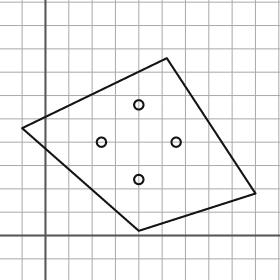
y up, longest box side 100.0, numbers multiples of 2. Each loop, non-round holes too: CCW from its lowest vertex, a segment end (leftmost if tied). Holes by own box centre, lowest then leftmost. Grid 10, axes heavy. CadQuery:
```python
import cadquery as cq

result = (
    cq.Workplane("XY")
    .moveTo(40.0, 2.0)
    .lineTo(90.0, 18.0)
    .lineTo(52.0, 76.0)
    .lineTo(-10.0, 46.0)
    .close()
    .moveTo(40.0, 24.0)
    .circle(2.0)
    .moveTo(24.0, 40.0)
    .circle(2.0)
    .moveTo(56.0, 40.0)
    .circle(2.0)
    .moveTo(40.0, 56.0)
    .circle(2.0)
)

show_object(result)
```